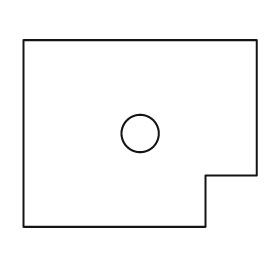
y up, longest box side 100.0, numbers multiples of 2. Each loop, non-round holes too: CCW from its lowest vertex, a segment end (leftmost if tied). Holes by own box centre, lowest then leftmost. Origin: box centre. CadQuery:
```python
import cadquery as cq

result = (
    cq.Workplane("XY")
    .moveTo(-50.0, -40.0)
    .lineTo(28.0, -40.0)
    .lineTo(28.0, -18.0)
    .lineTo(50.0, -18.0)
    .lineTo(50.0, 40.0)
    .lineTo(-50.0, 40.0)
    .close()
    .moveTo(0.0, 0.0)
    .circle(8.0)
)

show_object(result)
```